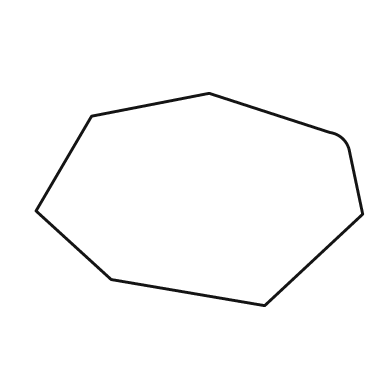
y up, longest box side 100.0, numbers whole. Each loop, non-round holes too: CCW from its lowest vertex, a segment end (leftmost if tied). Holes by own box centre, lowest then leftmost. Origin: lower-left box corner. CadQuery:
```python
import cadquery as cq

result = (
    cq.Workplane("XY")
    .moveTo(70.0, 0.0)
    .lineTo(100.0, 28.0)
    .lineTo(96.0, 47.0)
    .threePointArc((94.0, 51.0), (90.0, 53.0))
    .lineTo(53.0, 65.0)
    .lineTo(17.0, 58.0)
    .lineTo(0.0, 29.0)
    .lineTo(23.0, 8.0)
    .close()
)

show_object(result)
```